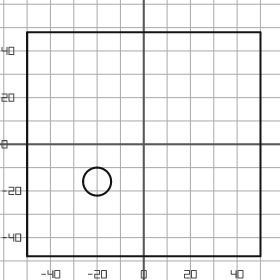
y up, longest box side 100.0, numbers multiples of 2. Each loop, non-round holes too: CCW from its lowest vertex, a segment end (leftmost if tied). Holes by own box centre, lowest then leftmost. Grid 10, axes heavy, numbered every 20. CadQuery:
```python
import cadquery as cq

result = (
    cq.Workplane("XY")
    .moveTo(-50.0, -48.0)
    .lineTo(50.0, -48.0)
    .lineTo(50.0, 48.0)
    .lineTo(-50.0, 48.0)
    .close()
    .moveTo(-20.0, -16.0)
    .circle(6.0)
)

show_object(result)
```